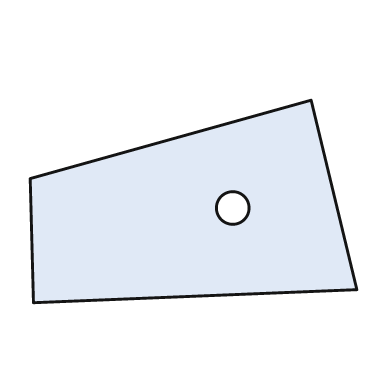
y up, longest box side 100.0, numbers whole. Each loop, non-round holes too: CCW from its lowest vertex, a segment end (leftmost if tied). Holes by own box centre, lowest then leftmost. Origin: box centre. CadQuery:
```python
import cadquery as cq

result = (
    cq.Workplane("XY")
    .moveTo(-49.0, -31.0)
    .lineTo(50.0, -27.0)
    .lineTo(36.0, 31.0)
    .lineTo(-50.0, 7.0)
    .close()
    .moveTo(12.0, -2.0)
    .circle(5.0)
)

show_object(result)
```